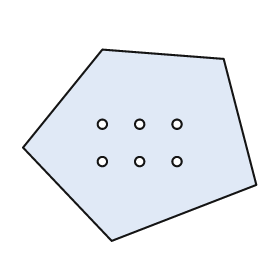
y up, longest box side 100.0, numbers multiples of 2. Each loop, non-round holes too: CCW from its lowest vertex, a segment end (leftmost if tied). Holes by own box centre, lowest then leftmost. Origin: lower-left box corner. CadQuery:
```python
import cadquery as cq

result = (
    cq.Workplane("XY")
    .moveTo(38.0, 0.0)
    .lineTo(100.0, 24.0)
    .lineTo(86.0, 78.0)
    .lineTo(34.0, 82.0)
    .lineTo(0.0, 40.0)
    .close()
    .moveTo(34.0, 34.0)
    .circle(2.0)
    .moveTo(50.0, 34.0)
    .circle(2.0)
    .moveTo(66.0, 34.0)
    .circle(2.0)
    .moveTo(34.0, 50.0)
    .circle(2.0)
    .moveTo(50.0, 50.0)
    .circle(2.0)
    .moveTo(66.0, 50.0)
    .circle(2.0)
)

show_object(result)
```